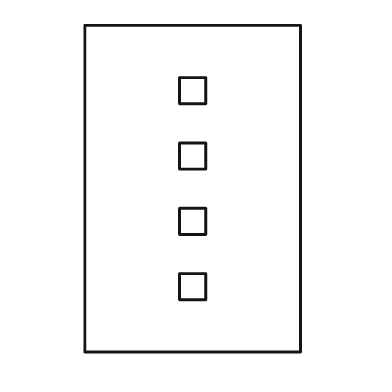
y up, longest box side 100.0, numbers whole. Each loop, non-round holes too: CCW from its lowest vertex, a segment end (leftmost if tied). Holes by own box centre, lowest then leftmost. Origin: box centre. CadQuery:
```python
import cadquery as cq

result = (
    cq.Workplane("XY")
    .moveTo(-33.0, -50.0)
    .lineTo(33.0, -50.0)
    .lineTo(33.0, 50.0)
    .lineTo(-33.0, 50.0)
    .close()
    .moveTo(-4.0, -34.0)
    .lineTo(4.0, -34.0)
    .lineTo(4.0, -26.0)
    .lineTo(-4.0, -26.0)
    .close()
    .moveTo(-4.0, -14.0)
    .lineTo(4.0, -14.0)
    .lineTo(4.0, -6.0)
    .lineTo(-4.0, -6.0)
    .close()
    .moveTo(-4.0, 6.0)
    .lineTo(4.0, 6.0)
    .lineTo(4.0, 14.0)
    .lineTo(-4.0, 14.0)
    .close()
    .moveTo(-4.0, 26.0)
    .lineTo(4.0, 26.0)
    .lineTo(4.0, 34.0)
    .lineTo(-4.0, 34.0)
    .close()
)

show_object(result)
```